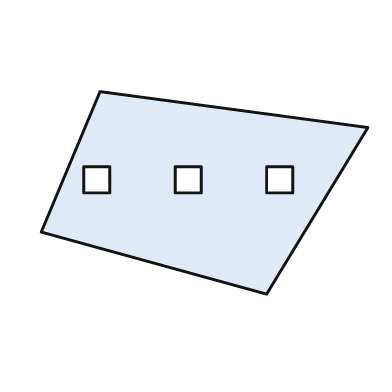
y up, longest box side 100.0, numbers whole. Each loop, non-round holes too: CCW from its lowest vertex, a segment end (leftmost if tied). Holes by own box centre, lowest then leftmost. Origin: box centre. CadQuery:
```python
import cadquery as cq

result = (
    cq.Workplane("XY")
    .moveTo(19.0, -31.0)
    .lineTo(50.0, 20.0)
    .lineTo(-32.0, 31.0)
    .lineTo(-50.0, -12.0)
    .close()
    .moveTo(-37.0, 0.0)
    .lineTo(-29.0, 0.0)
    .lineTo(-29.0, 8.0)
    .lineTo(-37.0, 8.0)
    .close()
    .moveTo(-9.0, 0.0)
    .lineTo(-1.0, 0.0)
    .lineTo(-1.0, 8.0)
    .lineTo(-9.0, 8.0)
    .close()
    .moveTo(19.0, 0.0)
    .lineTo(27.0, 0.0)
    .lineTo(27.0, 8.0)
    .lineTo(19.0, 8.0)
    .close()
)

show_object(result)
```